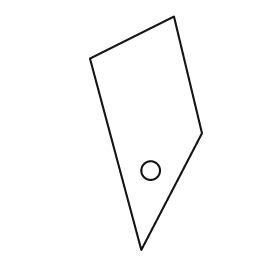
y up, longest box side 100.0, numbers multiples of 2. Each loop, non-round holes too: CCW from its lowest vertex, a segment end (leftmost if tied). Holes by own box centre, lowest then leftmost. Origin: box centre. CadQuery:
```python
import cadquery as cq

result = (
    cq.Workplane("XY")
    .moveTo(-2.0, -50.0)
    .lineTo(24.0, 0.0)
    .lineTo(12.0, 50.0)
    .lineTo(-24.0, 32.0)
    .close()
    .moveTo(2.0, -16.0)
    .circle(4.0)
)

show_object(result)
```